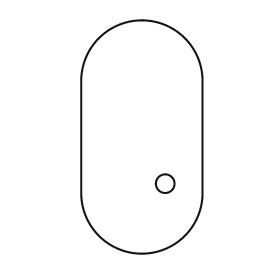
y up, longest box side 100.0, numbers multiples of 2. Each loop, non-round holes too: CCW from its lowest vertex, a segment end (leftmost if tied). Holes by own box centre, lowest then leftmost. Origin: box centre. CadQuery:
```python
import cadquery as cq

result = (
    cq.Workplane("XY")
    .moveTo(-26.0, -24.0)
    .threePointArc((0.0, -50.0), (26.0, -24.0))
    .lineTo(26.0, 24.0)
    .threePointArc((0.0, 50.0), (-26.0, 24.0))
    .close()
    .moveTo(10.0, -20.0)
    .circle(4.0)
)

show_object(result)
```